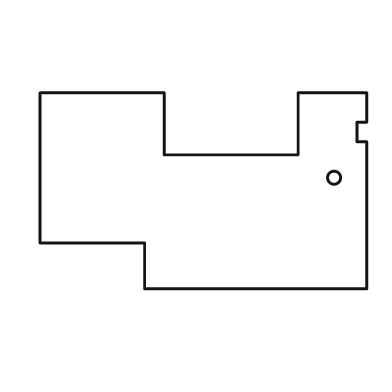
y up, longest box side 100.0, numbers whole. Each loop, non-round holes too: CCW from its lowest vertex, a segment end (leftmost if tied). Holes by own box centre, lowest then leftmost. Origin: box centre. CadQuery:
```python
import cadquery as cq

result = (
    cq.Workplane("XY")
    .moveTo(-18.0, -30.0)
    .lineTo(50.0, -30.0)
    .lineTo(50.0, 15.0)
    .lineTo(47.0, 15.0)
    .lineTo(47.0, 21.0)
    .lineTo(50.0, 21.0)
    .lineTo(50.0, 30.0)
    .lineTo(29.0, 30.0)
    .lineTo(29.0, 11.0)
    .lineTo(-12.0, 11.0)
    .lineTo(-12.0, 30.0)
    .lineTo(-50.0, 30.0)
    .lineTo(-50.0, -16.0)
    .lineTo(-18.0, -16.0)
    .close()
    .moveTo(40.0, 4.0)
    .circle(2.0)
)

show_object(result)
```